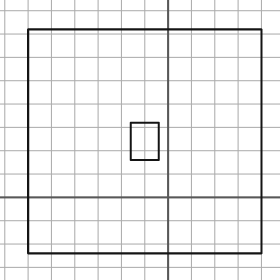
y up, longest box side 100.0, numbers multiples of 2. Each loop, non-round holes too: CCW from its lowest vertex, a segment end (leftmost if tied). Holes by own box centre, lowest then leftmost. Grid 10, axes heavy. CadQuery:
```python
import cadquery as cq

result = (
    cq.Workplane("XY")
    .moveTo(-60.0, -24.0)
    .lineTo(40.0, -24.0)
    .lineTo(40.0, 72.0)
    .lineTo(-60.0, 72.0)
    .close()
    .moveTo(-16.0, 16.0)
    .lineTo(-4.0, 16.0)
    .lineTo(-4.0, 32.0)
    .lineTo(-16.0, 32.0)
    .close()
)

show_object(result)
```